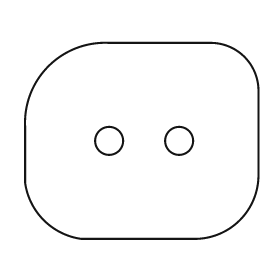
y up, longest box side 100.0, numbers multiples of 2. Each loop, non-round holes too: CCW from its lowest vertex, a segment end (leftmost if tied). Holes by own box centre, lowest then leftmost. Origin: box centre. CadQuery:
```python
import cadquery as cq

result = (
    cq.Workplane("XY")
    .moveTo(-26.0, -42.0)
    .lineTo(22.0, -42.0)
    .threePointArc((42.0, -34.0), (50.0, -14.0))
    .lineTo(50.0, 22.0)
    .threePointArc((44.0, 36.0), (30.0, 42.0))
    .lineTo(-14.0, 42.0)
    .threePointArc((-40.0, 32.0), (-50.0, 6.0))
    .lineTo(-50.0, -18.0)
    .threePointArc((-42.0, -34.0), (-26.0, -42.0))
    .close()
    .moveTo(-14.0, 0.0)
    .circle(6.0)
    .moveTo(16.0, 0.0)
    .circle(6.0)
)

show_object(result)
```